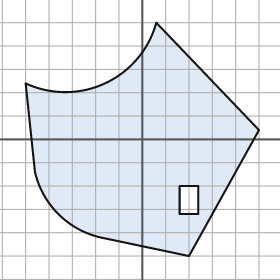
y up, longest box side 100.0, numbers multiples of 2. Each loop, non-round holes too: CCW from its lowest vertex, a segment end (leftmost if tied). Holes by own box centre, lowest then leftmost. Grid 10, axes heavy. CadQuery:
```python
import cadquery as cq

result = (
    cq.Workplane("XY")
    .moveTo(20.0, -50.0)
    .lineTo(50.0, 4.0)
    .lineTo(6.0, 50.0)
    .threePointArc((-16.0, 24.0), (-50.0, 24.0))
    .lineTo(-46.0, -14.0)
    .threePointArc((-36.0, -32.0), (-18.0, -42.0))
    .close()
    .moveTo(16.0, -32.0)
    .lineTo(24.0, -32.0)
    .lineTo(24.0, -20.0)
    .lineTo(16.0, -20.0)
    .close()
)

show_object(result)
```